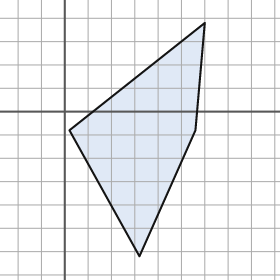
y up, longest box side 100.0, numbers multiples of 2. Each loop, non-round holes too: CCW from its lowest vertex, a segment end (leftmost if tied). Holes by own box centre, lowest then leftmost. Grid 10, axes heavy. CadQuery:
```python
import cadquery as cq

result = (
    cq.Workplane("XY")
    .moveTo(32.0, -62.0)
    .lineTo(56.0, -8.0)
    .lineTo(60.0, 38.0)
    .lineTo(2.0, -8.0)
    .close()
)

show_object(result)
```